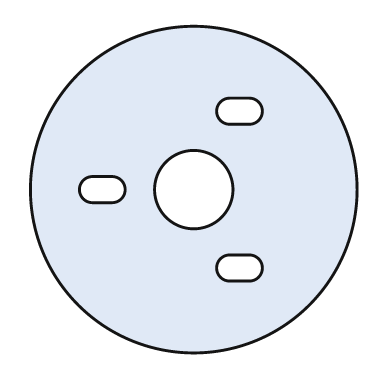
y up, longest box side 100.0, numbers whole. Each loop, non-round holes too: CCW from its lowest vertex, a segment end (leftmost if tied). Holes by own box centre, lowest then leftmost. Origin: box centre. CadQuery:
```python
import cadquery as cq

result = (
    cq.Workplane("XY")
    .moveTo(0.0, 0.0)
    .circle(50.0)
    .moveTo(11.0, -28.0)
    .lineTo(17.0, -28.0)
    .threePointArc((21.0, -24.0), (17.0, -20.0))
    .lineTo(11.0, -20.0)
    .threePointArc((7.0, -24.0), (11.0, -28.0))
    .close()
    .moveTo(-31.0, -4.0)
    .lineTo(-25.0, -4.0)
    .threePointArc((-21.0, 0.0), (-25.0, 4.0))
    .lineTo(-31.0, 4.0)
    .threePointArc((-35.0, 0.0), (-31.0, -4.0))
    .close()
    .moveTo(0.0, 0.0)
    .circle(12.0)
    .moveTo(11.0, 20.0)
    .lineTo(17.0, 20.0)
    .threePointArc((21.0, 24.0), (17.0, 28.0))
    .lineTo(11.0, 28.0)
    .threePointArc((7.0, 24.0), (11.0, 20.0))
    .close()
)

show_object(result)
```